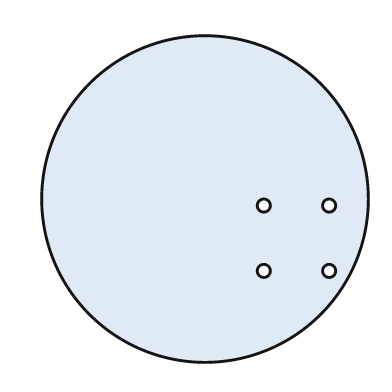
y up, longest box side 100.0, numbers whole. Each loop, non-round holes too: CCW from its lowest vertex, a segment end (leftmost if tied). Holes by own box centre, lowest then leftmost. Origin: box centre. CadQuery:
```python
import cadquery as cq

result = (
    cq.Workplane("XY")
    .moveTo(0.0, 0.0)
    .circle(50.0)
    .moveTo(18.0, -22.0)
    .circle(2.0)
    .moveTo(38.0, -22.0)
    .circle(2.0)
    .moveTo(18.0, -2.0)
    .circle(2.0)
    .moveTo(38.0, -2.0)
    .circle(2.0)
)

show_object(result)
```